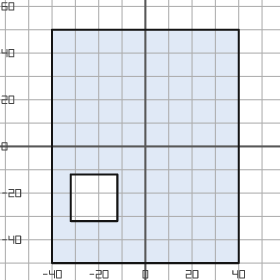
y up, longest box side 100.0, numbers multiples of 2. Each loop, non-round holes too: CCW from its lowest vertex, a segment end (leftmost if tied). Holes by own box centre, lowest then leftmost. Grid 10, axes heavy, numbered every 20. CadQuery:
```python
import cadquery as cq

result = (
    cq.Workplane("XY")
    .moveTo(-40.0, -50.0)
    .lineTo(40.0, -50.0)
    .lineTo(40.0, 50.0)
    .lineTo(-40.0, 50.0)
    .close()
    .moveTo(-32.0, -32.0)
    .lineTo(-12.0, -32.0)
    .lineTo(-12.0, -12.0)
    .lineTo(-32.0, -12.0)
    .close()
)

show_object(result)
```